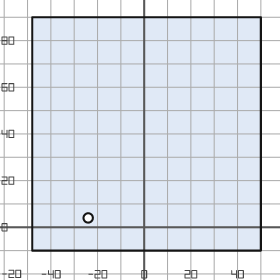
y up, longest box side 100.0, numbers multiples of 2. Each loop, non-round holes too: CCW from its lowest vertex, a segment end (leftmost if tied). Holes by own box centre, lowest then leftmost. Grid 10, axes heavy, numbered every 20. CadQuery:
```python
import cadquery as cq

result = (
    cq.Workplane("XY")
    .moveTo(-48.0, -10.0)
    .lineTo(50.0, -10.0)
    .lineTo(50.0, 90.0)
    .lineTo(-48.0, 90.0)
    .close()
    .moveTo(-24.0, 4.0)
    .circle(2.0)
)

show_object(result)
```